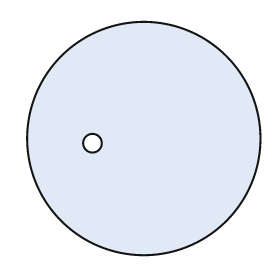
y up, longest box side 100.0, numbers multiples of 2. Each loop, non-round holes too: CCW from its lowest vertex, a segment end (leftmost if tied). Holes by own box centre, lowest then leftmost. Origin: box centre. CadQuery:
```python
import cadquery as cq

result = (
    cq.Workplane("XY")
    .moveTo(0.0, 0.0)
    .circle(50.0)
    .moveTo(-22.0, -2.0)
    .circle(4.0)
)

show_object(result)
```